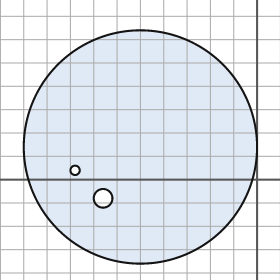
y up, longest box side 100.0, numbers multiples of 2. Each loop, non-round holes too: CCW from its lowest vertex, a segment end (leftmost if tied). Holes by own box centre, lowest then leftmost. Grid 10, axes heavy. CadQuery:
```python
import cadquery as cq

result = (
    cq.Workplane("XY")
    .moveTo(-50.0, 14.0)
    .circle(50.0)
    .moveTo(-66.0, -8.0)
    .circle(4.0)
    .moveTo(-78.0, 4.0)
    .circle(2.0)
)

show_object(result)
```